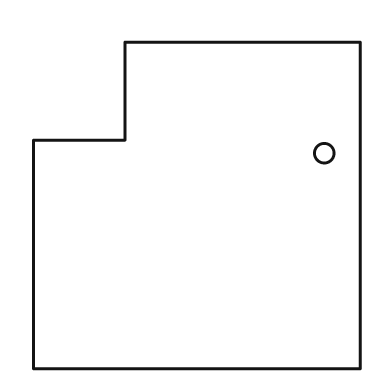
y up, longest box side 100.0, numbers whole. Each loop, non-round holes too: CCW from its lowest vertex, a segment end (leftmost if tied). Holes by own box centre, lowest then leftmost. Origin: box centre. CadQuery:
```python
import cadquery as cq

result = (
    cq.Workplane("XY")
    .moveTo(-50.0, -50.0)
    .lineTo(50.0, -50.0)
    .lineTo(50.0, 50.0)
    .lineTo(-22.0, 50.0)
    .lineTo(-22.0, 20.0)
    .lineTo(-50.0, 20.0)
    .close()
    .moveTo(39.0, 16.0)
    .circle(3.0)
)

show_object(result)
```